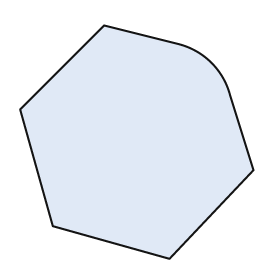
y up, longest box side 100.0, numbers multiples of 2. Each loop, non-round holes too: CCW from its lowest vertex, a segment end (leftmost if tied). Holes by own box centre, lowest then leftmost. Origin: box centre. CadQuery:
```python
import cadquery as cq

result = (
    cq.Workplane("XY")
    .moveTo(14.0, -50.0)
    .lineTo(50.0, -12.0)
    .lineTo(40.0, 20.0)
    .threePointArc((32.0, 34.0), (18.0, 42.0))
    .lineTo(-14.0, 50.0)
    .lineTo(-50.0, 14.0)
    .lineTo(-36.0, -36.0)
    .close()
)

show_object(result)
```